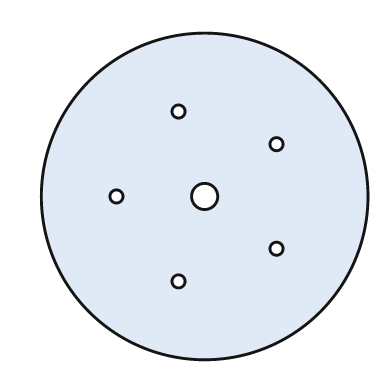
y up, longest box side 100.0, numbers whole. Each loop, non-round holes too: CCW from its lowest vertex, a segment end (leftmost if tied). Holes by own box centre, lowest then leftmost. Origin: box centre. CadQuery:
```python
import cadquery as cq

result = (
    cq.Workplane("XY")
    .moveTo(0.0, 0.0)
    .circle(50.0)
    .moveTo(-8.0, -26.0)
    .circle(2.0)
    .moveTo(22.0, -16.0)
    .circle(2.0)
    .moveTo(-27.0, 0.0)
    .circle(2.0)
    .moveTo(0.0, 0.0)
    .circle(4.0)
    .moveTo(22.0, 16.0)
    .circle(2.0)
    .moveTo(-8.0, 26.0)
    .circle(2.0)
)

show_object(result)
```